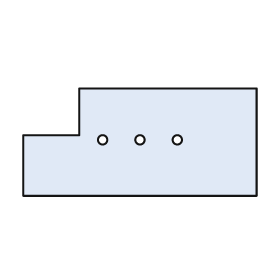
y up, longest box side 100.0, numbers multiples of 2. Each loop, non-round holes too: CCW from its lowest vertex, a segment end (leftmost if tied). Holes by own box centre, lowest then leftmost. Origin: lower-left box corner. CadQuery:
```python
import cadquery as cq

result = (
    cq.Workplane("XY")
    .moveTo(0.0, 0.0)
    .lineTo(100.0, 0.0)
    .lineTo(100.0, 46.0)
    .lineTo(24.0, 46.0)
    .lineTo(24.0, 26.0)
    .lineTo(0.0, 26.0)
    .close()
    .moveTo(34.0, 24.0)
    .circle(2.0)
    .moveTo(50.0, 24.0)
    .circle(2.0)
    .moveTo(66.0, 24.0)
    .circle(2.0)
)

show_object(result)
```